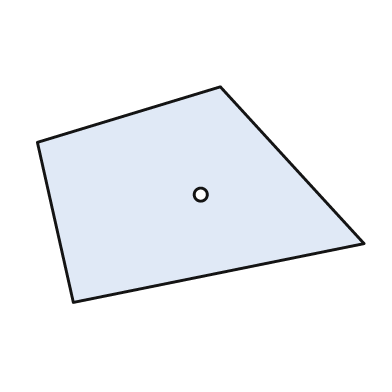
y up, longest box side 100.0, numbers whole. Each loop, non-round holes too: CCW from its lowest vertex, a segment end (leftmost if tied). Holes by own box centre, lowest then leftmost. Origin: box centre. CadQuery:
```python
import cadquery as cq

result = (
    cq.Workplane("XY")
    .moveTo(-39.0, -33.0)
    .lineTo(50.0, -15.0)
    .lineTo(6.0, 33.0)
    .lineTo(-50.0, 16.0)
    .close()
    .moveTo(0.0, 0.0)
    .circle(2.0)
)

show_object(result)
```